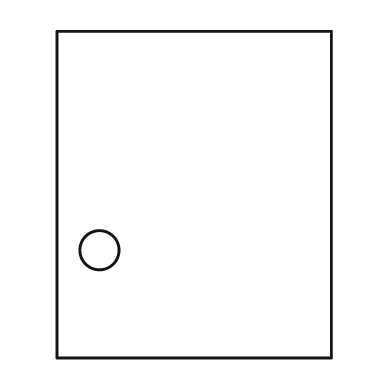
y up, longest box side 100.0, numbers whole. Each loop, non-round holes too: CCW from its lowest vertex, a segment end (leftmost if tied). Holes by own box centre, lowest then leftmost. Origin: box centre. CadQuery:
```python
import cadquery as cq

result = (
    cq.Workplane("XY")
    .moveTo(-42.0, -50.0)
    .lineTo(42.0, -50.0)
    .lineTo(42.0, 50.0)
    .lineTo(-42.0, 50.0)
    .close()
    .moveTo(-29.0, -17.0)
    .circle(6.0)
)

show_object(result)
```